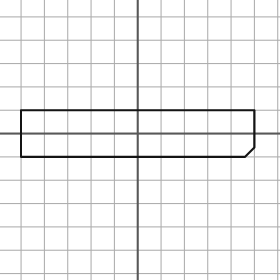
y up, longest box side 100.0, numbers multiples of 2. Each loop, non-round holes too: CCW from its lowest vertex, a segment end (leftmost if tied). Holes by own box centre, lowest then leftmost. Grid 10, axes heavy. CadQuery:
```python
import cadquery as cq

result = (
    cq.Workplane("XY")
    .moveTo(-50.0, -10.0)
    .lineTo(46.0, -10.0)
    .lineTo(50.0, -6.0)
    .lineTo(50.0, 10.0)
    .lineTo(-50.0, 10.0)
    .close()
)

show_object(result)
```